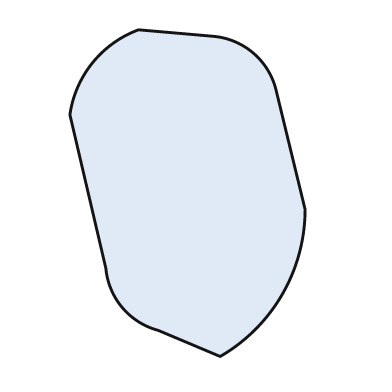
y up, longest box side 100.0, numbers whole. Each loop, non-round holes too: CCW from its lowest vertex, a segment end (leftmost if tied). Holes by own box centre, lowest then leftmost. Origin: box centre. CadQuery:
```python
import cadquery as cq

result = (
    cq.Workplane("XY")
    .moveTo(10.0, -50.0)
    .threePointArc((29.0, -31.0), (36.0, -5.0))
    .lineTo(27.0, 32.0)
    .threePointArc((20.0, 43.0), (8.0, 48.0))
    .lineTo(-15.0, 50.0)
    .threePointArc((-29.0, 40.0), (-36.0, 24.0))
    .lineTo(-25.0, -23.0)
    .threePointArc((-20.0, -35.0), (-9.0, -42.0))
    .close()
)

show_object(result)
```